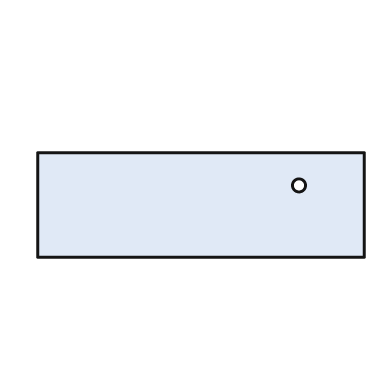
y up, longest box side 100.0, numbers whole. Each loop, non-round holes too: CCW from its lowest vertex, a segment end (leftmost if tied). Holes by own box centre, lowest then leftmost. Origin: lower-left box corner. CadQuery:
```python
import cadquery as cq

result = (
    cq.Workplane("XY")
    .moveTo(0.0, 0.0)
    .lineTo(100.0, 0.0)
    .lineTo(100.0, 32.0)
    .lineTo(0.0, 32.0)
    .close()
    .moveTo(80.0, 22.0)
    .circle(2.0)
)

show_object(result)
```